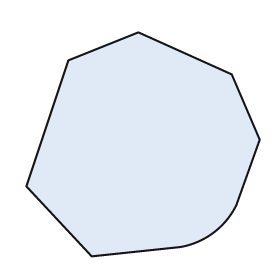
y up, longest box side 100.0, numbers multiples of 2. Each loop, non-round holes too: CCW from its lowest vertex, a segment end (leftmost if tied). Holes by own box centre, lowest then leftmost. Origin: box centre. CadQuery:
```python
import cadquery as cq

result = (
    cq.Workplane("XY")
    .moveTo(-22.0, -48.0)
    .lineTo(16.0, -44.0)
    .threePointArc((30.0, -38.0), (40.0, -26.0))
    .lineTo(50.0, 2.0)
    .lineTo(38.0, 30.0)
    .lineTo(-2.0, 48.0)
    .lineTo(-32.0, 36.0)
    .lineTo(-50.0, -18.0)
    .close()
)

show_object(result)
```